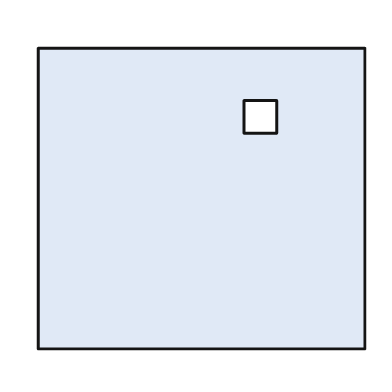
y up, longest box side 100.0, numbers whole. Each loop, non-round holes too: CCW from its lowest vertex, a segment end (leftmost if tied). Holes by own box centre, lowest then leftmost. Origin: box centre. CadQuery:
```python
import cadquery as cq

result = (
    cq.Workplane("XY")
    .moveTo(-50.0, -46.0)
    .lineTo(50.0, -46.0)
    .lineTo(50.0, 46.0)
    .lineTo(-50.0, 46.0)
    .close()
    .moveTo(13.0, 20.0)
    .lineTo(23.0, 20.0)
    .lineTo(23.0, 30.0)
    .lineTo(13.0, 30.0)
    .close()
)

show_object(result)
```